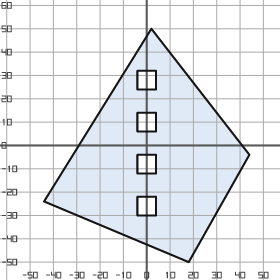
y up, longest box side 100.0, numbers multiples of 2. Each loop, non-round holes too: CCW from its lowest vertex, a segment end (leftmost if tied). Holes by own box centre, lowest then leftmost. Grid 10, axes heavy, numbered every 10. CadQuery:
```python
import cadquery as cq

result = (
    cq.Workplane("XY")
    .moveTo(18.0, -50.0)
    .lineTo(44.0, -4.0)
    .lineTo(2.0, 50.0)
    .lineTo(-44.0, -24.0)
    .close()
    .moveTo(-4.0, -30.0)
    .lineTo(4.0, -30.0)
    .lineTo(4.0, -22.0)
    .lineTo(-4.0, -22.0)
    .close()
    .moveTo(-4.0, -12.0)
    .lineTo(4.0, -12.0)
    .lineTo(4.0, -4.0)
    .lineTo(-4.0, -4.0)
    .close()
    .moveTo(-4.0, 6.0)
    .lineTo(4.0, 6.0)
    .lineTo(4.0, 14.0)
    .lineTo(-4.0, 14.0)
    .close()
    .moveTo(-4.0, 24.0)
    .lineTo(4.0, 24.0)
    .lineTo(4.0, 32.0)
    .lineTo(-4.0, 32.0)
    .close()
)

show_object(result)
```